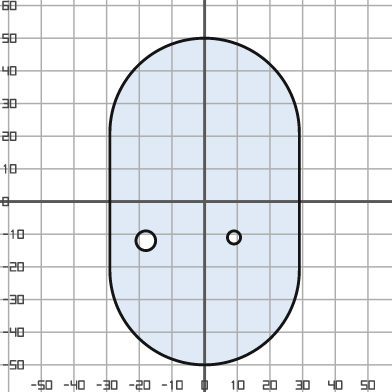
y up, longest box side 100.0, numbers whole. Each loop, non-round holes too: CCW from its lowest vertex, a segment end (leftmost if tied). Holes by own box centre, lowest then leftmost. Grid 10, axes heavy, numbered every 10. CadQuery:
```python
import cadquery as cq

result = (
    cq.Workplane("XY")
    .moveTo(-29.0, -21.0)
    .threePointArc((0.0, -50.0), (29.0, -21.0))
    .lineTo(29.0, 21.0)
    .threePointArc((0.0, 50.0), (-29.0, 21.0))
    .close()
    .moveTo(-18.0, -12.0)
    .circle(3.0)
    .moveTo(9.0, -11.0)
    .circle(2.0)
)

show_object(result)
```